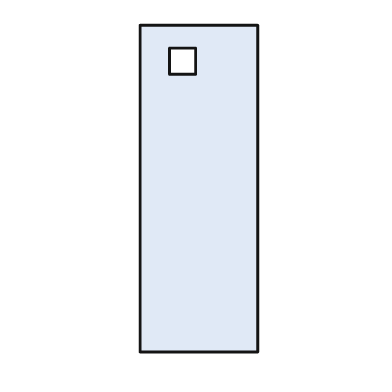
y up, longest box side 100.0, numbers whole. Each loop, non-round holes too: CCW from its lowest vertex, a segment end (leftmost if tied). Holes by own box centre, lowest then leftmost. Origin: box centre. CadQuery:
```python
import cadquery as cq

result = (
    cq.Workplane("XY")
    .moveTo(-18.0, -50.0)
    .lineTo(18.0, -50.0)
    .lineTo(18.0, 50.0)
    .lineTo(-18.0, 50.0)
    .close()
    .moveTo(-9.0, 35.0)
    .lineTo(-1.0, 35.0)
    .lineTo(-1.0, 43.0)
    .lineTo(-9.0, 43.0)
    .close()
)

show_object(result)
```